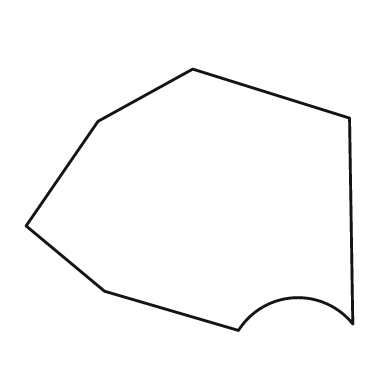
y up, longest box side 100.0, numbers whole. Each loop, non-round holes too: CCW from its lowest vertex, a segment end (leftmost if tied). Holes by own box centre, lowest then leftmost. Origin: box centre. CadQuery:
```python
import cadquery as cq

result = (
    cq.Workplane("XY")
    .moveTo(15.0, -40.0)
    .threePointArc((32.0, -30.0), (50.0, -38.0))
    .lineTo(49.0, 25.0)
    .lineTo(1.0, 40.0)
    .lineTo(-28.0, 24.0)
    .lineTo(-50.0, -8.0)
    .lineTo(-26.0, -28.0)
    .close()
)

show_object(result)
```